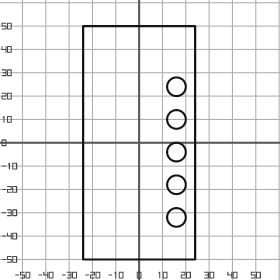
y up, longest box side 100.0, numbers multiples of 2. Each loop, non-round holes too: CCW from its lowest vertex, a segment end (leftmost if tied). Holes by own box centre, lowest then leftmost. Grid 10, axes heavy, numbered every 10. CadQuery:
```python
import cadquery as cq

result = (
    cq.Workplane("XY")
    .moveTo(-24.0, -50.0)
    .lineTo(24.0, -50.0)
    .lineTo(24.0, 50.0)
    .lineTo(-24.0, 50.0)
    .close()
    .moveTo(16.0, -32.0)
    .circle(4.0)
    .moveTo(16.0, -18.0)
    .circle(4.0)
    .moveTo(16.0, -4.0)
    .circle(4.0)
    .moveTo(16.0, 10.0)
    .circle(4.0)
    .moveTo(16.0, 24.0)
    .circle(4.0)
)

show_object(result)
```